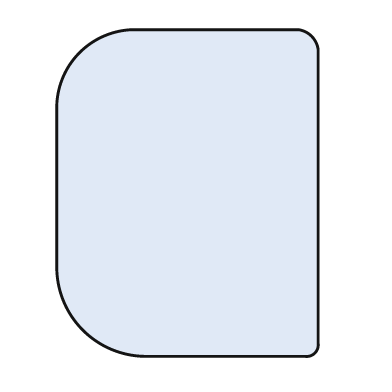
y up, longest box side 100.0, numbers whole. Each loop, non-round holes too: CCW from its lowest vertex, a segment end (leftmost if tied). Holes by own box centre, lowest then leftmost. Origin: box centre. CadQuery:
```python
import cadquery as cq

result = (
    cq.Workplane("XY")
    .moveTo(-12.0, -50.0)
    .lineTo(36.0, -50.0)
    .threePointArc((39.0, -49.0), (40.0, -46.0))
    .lineTo(40.0, 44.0)
    .threePointArc((38.0, 48.0), (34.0, 50.0))
    .lineTo(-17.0, 50.0)
    .threePointArc((-33.0, 43.0), (-40.0, 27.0))
    .lineTo(-40.0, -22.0)
    .threePointArc((-32.0, -42.0), (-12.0, -50.0))
    .close()
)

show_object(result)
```